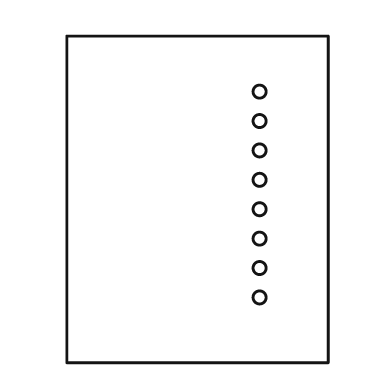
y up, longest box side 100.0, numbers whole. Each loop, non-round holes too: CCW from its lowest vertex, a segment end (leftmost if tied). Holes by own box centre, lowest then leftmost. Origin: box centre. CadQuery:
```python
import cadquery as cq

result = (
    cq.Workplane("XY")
    .moveTo(-40.0, -50.0)
    .lineTo(40.0, -50.0)
    .lineTo(40.0, 50.0)
    .lineTo(-40.0, 50.0)
    .close()
    .moveTo(19.0, -30.0)
    .circle(2.0)
    .moveTo(19.0, -21.0)
    .circle(2.0)
    .moveTo(19.0, -12.0)
    .circle(2.0)
    .moveTo(19.0, -3.0)
    .circle(2.0)
    .moveTo(19.0, 6.0)
    .circle(2.0)
    .moveTo(19.0, 15.0)
    .circle(2.0)
    .moveTo(19.0, 24.0)
    .circle(2.0)
    .moveTo(19.0, 33.0)
    .circle(2.0)
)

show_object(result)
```